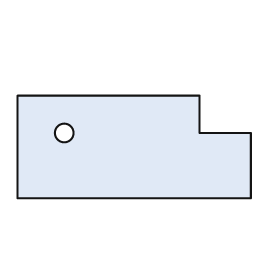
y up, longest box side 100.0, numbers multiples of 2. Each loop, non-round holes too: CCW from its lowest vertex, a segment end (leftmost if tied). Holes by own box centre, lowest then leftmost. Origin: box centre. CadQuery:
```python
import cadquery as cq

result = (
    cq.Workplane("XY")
    .moveTo(-50.0, -22.0)
    .lineTo(50.0, -22.0)
    .lineTo(50.0, 6.0)
    .lineTo(28.0, 6.0)
    .lineTo(28.0, 22.0)
    .lineTo(-50.0, 22.0)
    .close()
    .moveTo(-30.0, 6.0)
    .circle(4.0)
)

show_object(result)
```